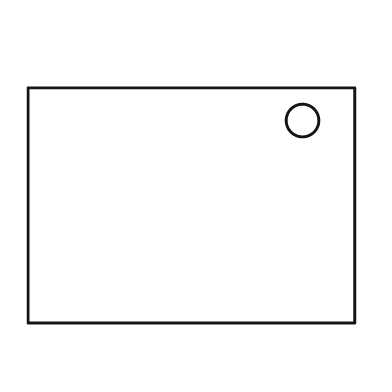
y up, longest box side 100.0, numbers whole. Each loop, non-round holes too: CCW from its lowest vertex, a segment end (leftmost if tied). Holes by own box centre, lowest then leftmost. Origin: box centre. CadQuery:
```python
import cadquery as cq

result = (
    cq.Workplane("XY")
    .moveTo(-50.0, -36.0)
    .lineTo(50.0, -36.0)
    .lineTo(50.0, 36.0)
    .lineTo(-50.0, 36.0)
    .close()
    .moveTo(34.0, 26.0)
    .circle(5.0)
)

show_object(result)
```